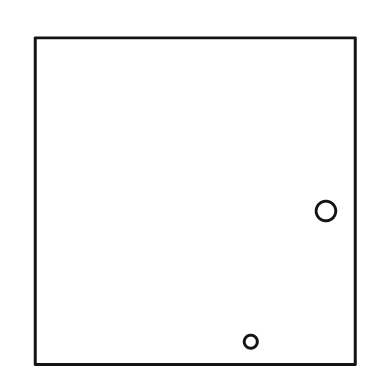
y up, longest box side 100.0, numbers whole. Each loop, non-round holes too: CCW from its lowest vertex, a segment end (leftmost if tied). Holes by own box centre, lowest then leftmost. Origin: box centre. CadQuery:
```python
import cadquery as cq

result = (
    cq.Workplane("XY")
    .moveTo(-49.0, -50.0)
    .lineTo(49.0, -50.0)
    .lineTo(49.0, 50.0)
    .lineTo(-49.0, 50.0)
    .close()
    .moveTo(17.0, -43.0)
    .circle(2.0)
    .moveTo(40.0, -3.0)
    .circle(3.0)
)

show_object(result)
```